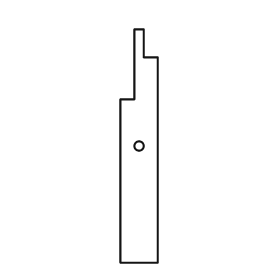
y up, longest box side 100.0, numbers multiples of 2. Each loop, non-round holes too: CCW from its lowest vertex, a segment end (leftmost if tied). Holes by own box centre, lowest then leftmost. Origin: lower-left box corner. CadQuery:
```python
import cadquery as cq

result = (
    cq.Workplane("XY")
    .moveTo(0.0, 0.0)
    .lineTo(16.0, 0.0)
    .lineTo(16.0, 88.0)
    .lineTo(10.0, 88.0)
    .lineTo(10.0, 100.0)
    .lineTo(6.0, 100.0)
    .lineTo(6.0, 70.0)
    .lineTo(0.0, 70.0)
    .close()
    .moveTo(8.0, 50.0)
    .circle(2.0)
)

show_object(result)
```